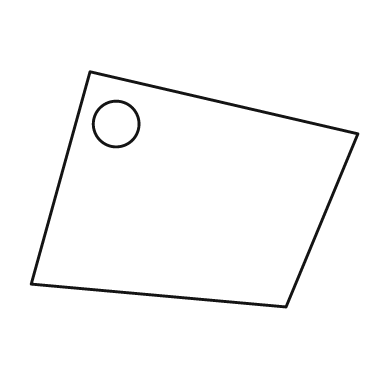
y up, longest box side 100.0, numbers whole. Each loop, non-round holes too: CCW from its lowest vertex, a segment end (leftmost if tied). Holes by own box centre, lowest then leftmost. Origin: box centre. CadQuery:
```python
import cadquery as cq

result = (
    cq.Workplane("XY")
    .moveTo(28.0, -36.0)
    .lineTo(50.0, 17.0)
    .lineTo(-32.0, 36.0)
    .lineTo(-50.0, -29.0)
    .close()
    .moveTo(-24.0, 20.0)
    .circle(7.0)
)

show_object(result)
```